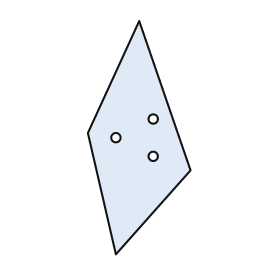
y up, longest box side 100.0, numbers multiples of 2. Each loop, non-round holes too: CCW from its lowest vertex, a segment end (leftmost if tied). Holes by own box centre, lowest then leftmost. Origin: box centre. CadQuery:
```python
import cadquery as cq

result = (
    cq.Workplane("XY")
    .moveTo(-10.0, -50.0)
    .lineTo(22.0, -14.0)
    .lineTo(0.0, 50.0)
    .lineTo(-22.0, 2.0)
    .close()
    .moveTo(6.0, -8.0)
    .circle(2.0)
    .moveTo(-10.0, 0.0)
    .circle(2.0)
    .moveTo(6.0, 8.0)
    .circle(2.0)
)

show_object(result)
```